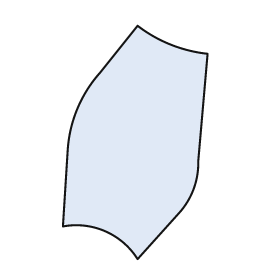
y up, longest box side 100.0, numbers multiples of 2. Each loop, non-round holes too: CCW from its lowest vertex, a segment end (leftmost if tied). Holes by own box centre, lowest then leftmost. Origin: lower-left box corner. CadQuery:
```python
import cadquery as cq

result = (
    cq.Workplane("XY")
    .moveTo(32.0, 0.0)
    .lineTo(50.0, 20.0)
    .threePointArc((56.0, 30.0), (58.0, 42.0))
    .lineTo(62.0, 88.0)
    .threePointArc((46.0, 92.0), (32.0, 100.0))
    .lineTo(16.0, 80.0)
    .threePointArc((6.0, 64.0), (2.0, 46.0))
    .lineTo(0.0, 14.0)
    .threePointArc((18.0, 12.0), (32.0, 0.0))
    .close()
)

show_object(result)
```